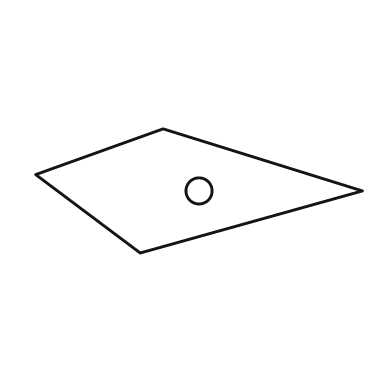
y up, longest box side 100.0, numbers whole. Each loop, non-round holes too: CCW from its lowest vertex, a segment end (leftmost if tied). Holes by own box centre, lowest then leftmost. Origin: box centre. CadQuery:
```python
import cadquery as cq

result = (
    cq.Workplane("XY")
    .moveTo(-18.0, -19.0)
    .lineTo(50.0, 0.0)
    .lineTo(-11.0, 19.0)
    .lineTo(-50.0, 5.0)
    .close()
    .moveTo(0.0, 0.0)
    .circle(4.0)
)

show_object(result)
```